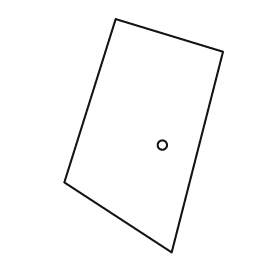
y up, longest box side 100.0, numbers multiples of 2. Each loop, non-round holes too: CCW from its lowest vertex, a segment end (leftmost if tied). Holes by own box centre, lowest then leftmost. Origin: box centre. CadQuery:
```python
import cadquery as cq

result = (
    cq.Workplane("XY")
    .moveTo(12.0, -50.0)
    .lineTo(34.0, 36.0)
    .lineTo(-12.0, 50.0)
    .lineTo(-34.0, -20.0)
    .close()
    .moveTo(8.0, -4.0)
    .circle(2.0)
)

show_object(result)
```